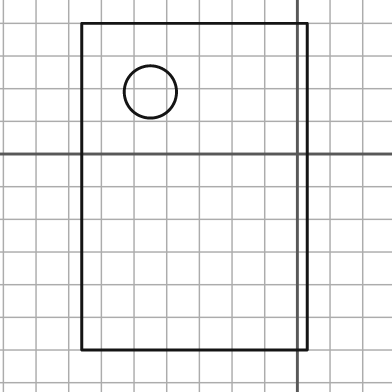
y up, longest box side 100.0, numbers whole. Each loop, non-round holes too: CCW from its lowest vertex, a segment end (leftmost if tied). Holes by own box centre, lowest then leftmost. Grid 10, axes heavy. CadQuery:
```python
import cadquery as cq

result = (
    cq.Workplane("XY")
    .moveTo(-66.0, -60.0)
    .lineTo(3.0, -60.0)
    .lineTo(3.0, 40.0)
    .lineTo(-66.0, 40.0)
    .close()
    .moveTo(-45.0, 19.0)
    .circle(8.0)
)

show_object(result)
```